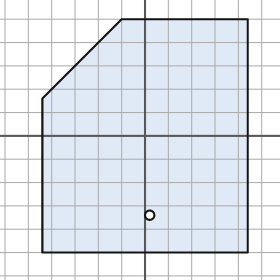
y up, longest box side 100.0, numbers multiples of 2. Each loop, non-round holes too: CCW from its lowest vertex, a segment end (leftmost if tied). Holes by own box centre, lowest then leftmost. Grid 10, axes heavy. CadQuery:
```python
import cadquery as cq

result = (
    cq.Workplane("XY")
    .moveTo(-44.0, -50.0)
    .lineTo(44.0, -50.0)
    .lineTo(44.0, 50.0)
    .lineTo(-10.0, 50.0)
    .lineTo(-44.0, 16.0)
    .close()
    .moveTo(2.0, -34.0)
    .circle(2.0)
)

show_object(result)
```